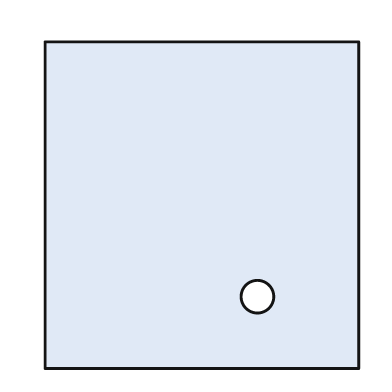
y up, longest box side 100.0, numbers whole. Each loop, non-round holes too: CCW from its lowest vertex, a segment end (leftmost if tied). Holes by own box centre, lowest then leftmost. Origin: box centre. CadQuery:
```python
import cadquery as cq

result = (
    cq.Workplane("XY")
    .moveTo(-48.0, -50.0)
    .lineTo(48.0, -50.0)
    .lineTo(48.0, 50.0)
    .lineTo(-48.0, 50.0)
    .close()
    .moveTo(17.0, -28.0)
    .circle(5.0)
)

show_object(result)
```